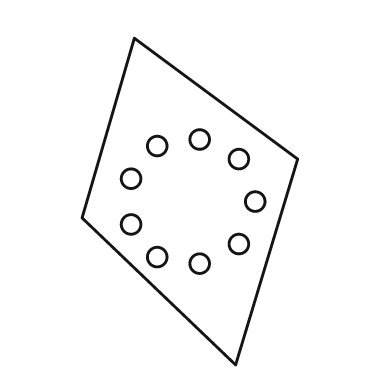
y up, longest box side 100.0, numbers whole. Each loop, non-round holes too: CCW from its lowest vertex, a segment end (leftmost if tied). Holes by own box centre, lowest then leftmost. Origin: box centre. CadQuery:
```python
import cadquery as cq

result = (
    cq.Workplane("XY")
    .moveTo(14.0, -50.0)
    .lineTo(33.0, 13.0)
    .lineTo(-17.0, 50.0)
    .lineTo(-33.0, -5.0)
    .close()
    .moveTo(3.0, -19.0)
    .circle(3.0)
    .moveTo(-10.0, -17.0)
    .circle(3.0)
    .moveTo(15.0, -13.0)
    .circle(3.0)
    .moveTo(-18.0, -7.0)
    .circle(3.0)
    .moveTo(20.0, 0.0)
    .circle(3.0)
    .moveTo(-18.0, 7.0)
    .circle(3.0)
    .moveTo(15.0, 13.0)
    .circle(3.0)
    .moveTo(-10.0, 17.0)
    .circle(3.0)
    .moveTo(3.0, 19.0)
    .circle(3.0)
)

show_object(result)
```